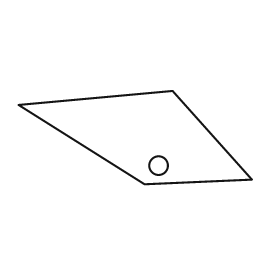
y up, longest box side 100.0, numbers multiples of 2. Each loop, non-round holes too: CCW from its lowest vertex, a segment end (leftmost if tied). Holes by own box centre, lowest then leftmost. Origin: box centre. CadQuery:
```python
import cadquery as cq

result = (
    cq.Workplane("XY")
    .moveTo(4.0, -20.0)
    .lineTo(50.0, -18.0)
    .lineTo(16.0, 20.0)
    .lineTo(-50.0, 14.0)
    .close()
    .moveTo(10.0, -12.0)
    .circle(4.0)
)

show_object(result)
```